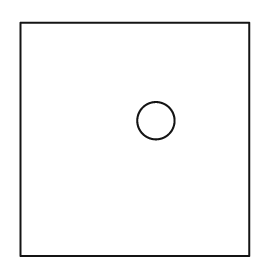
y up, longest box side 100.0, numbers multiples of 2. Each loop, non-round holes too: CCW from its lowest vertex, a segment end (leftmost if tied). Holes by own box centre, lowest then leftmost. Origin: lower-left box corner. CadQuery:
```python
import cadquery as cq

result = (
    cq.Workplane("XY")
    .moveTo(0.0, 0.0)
    .lineTo(98.0, 0.0)
    .lineTo(98.0, 100.0)
    .lineTo(0.0, 100.0)
    .close()
    .moveTo(58.0, 58.0)
    .circle(8.0)
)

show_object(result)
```